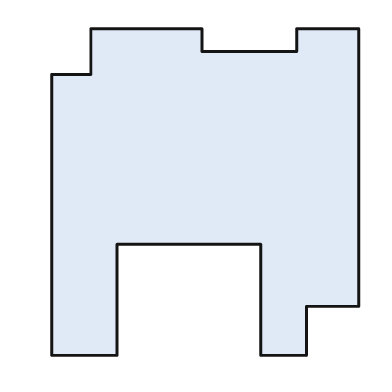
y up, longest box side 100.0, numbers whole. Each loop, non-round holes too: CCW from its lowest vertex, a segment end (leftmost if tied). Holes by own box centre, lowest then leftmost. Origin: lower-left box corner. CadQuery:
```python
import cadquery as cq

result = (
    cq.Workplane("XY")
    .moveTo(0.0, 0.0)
    .lineTo(20.0, 0.0)
    .lineTo(20.0, 34.0)
    .lineTo(64.0, 34.0)
    .lineTo(64.0, 0.0)
    .lineTo(78.0, 0.0)
    .lineTo(78.0, 15.0)
    .lineTo(94.0, 15.0)
    .lineTo(94.0, 100.0)
    .lineTo(75.0, 100.0)
    .lineTo(75.0, 93.0)
    .lineTo(46.0, 93.0)
    .lineTo(46.0, 100.0)
    .lineTo(12.0, 100.0)
    .lineTo(12.0, 86.0)
    .lineTo(0.0, 86.0)
    .close()
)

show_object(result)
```